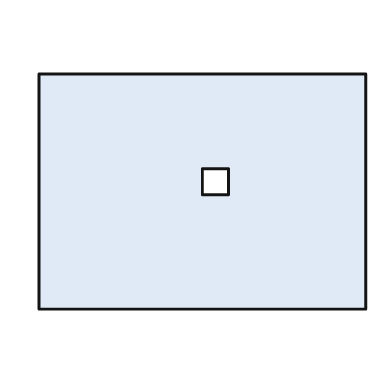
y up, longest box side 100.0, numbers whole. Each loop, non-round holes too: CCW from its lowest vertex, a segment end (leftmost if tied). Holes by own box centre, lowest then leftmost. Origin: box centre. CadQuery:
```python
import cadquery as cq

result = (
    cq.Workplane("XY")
    .moveTo(-50.0, -36.0)
    .lineTo(50.0, -36.0)
    .lineTo(50.0, 36.0)
    .lineTo(-50.0, 36.0)
    .close()
    .moveTo(0.0, -1.0)
    .lineTo(8.0, -1.0)
    .lineTo(8.0, 7.0)
    .lineTo(0.0, 7.0)
    .close()
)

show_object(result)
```